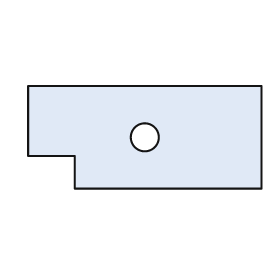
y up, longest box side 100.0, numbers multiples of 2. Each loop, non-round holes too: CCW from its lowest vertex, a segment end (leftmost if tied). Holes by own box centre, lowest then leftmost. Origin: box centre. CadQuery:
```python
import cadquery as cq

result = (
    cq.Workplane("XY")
    .moveTo(-30.0, -22.0)
    .lineTo(50.0, -22.0)
    .lineTo(50.0, 22.0)
    .lineTo(-50.0, 22.0)
    .lineTo(-50.0, -8.0)
    .lineTo(-30.0, -8.0)
    .close()
    .moveTo(0.0, 0.0)
    .circle(6.0)
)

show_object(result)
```